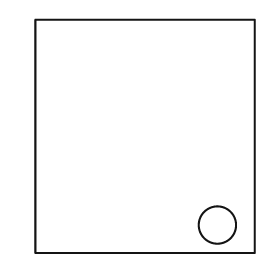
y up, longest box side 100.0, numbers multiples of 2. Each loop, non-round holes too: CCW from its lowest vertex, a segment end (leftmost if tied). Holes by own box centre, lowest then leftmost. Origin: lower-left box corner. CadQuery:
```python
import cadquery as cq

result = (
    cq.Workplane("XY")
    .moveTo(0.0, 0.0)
    .lineTo(94.0, 0.0)
    .lineTo(94.0, 100.0)
    .lineTo(0.0, 100.0)
    .close()
    .moveTo(78.0, 12.0)
    .circle(8.0)
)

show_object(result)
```